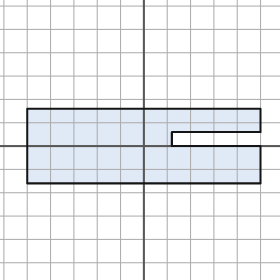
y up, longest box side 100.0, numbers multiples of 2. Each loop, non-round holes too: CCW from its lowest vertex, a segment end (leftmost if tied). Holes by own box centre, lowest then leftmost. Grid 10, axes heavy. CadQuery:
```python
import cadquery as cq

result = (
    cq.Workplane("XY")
    .moveTo(-50.0, -16.0)
    .lineTo(50.0, -16.0)
    .lineTo(50.0, 0.0)
    .lineTo(12.0, 0.0)
    .lineTo(12.0, 6.0)
    .lineTo(50.0, 6.0)
    .lineTo(50.0, 16.0)
    .lineTo(-50.0, 16.0)
    .close()
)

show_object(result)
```